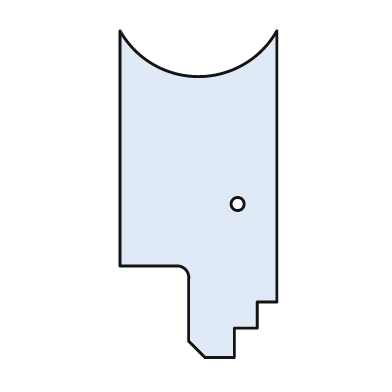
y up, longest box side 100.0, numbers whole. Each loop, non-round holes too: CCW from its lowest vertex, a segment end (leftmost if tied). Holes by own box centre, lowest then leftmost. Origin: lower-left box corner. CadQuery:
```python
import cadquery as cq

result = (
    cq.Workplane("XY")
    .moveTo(26.0, 0.0)
    .lineTo(35.0, 0.0)
    .lineTo(35.0, 9.0)
    .lineTo(42.0, 9.0)
    .lineTo(42.0, 17.0)
    .lineTo(48.0, 17.0)
    .lineTo(48.0, 100.0)
    .threePointArc((24.0, 86.0), (0.0, 100.0))
    .lineTo(0.0, 28.0)
    .lineTo(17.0, 28.0)
    .threePointArc((20.0, 27.0), (21.0, 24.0))
    .lineTo(21.0, 5.0)
    .close()
    .moveTo(36.0, 47.0)
    .circle(2.0)
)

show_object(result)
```